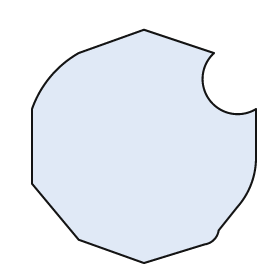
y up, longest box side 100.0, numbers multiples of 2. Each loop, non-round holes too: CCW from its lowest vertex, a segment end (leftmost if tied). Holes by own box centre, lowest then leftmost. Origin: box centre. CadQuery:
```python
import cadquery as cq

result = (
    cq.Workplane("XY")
    .moveTo(0.0, -50.0)
    .lineTo(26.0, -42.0)
    .threePointArc((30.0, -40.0), (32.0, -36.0))
    .lineTo(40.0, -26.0)
    .threePointArc((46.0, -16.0), (48.0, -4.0))
    .lineTo(48.0, 16.0)
    .threePointArc((28.0, 20.0), (30.0, 40.0))
    .lineTo(0.0, 50.0)
    .lineTo(-28.0, 40.0)
    .threePointArc((-40.0, 30.0), (-48.0, 16.0))
    .lineTo(-48.0, -16.0)
    .lineTo(-28.0, -40.0)
    .close()
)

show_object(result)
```